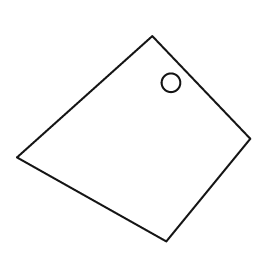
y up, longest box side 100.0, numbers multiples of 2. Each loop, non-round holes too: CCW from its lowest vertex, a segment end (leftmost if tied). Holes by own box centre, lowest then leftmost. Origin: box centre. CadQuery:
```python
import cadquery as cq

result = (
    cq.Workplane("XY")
    .moveTo(14.0, -44.0)
    .lineTo(50.0, 0.0)
    .lineTo(8.0, 44.0)
    .lineTo(-50.0, -8.0)
    .close()
    .moveTo(16.0, 24.0)
    .circle(4.0)
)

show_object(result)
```